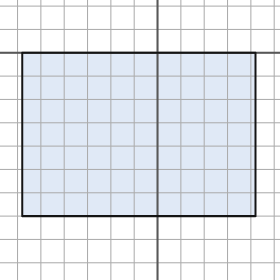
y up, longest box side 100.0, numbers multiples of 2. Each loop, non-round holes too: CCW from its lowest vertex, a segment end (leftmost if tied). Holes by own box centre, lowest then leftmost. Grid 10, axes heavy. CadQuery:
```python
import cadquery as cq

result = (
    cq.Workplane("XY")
    .moveTo(-58.0, -70.0)
    .lineTo(42.0, -70.0)
    .lineTo(42.0, 0.0)
    .lineTo(-58.0, 0.0)
    .close()
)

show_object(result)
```